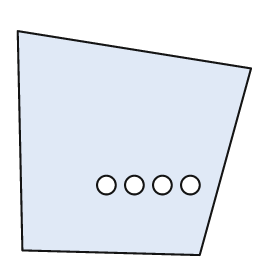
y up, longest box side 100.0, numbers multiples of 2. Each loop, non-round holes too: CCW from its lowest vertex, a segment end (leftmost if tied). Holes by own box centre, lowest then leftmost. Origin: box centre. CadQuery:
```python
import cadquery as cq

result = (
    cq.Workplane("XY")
    .moveTo(28.0, -48.0)
    .lineTo(50.0, 32.0)
    .lineTo(-50.0, 48.0)
    .lineTo(-48.0, -46.0)
    .close()
    .moveTo(-12.0, -18.0)
    .circle(4.0)
    .moveTo(0.0, -18.0)
    .circle(4.0)
    .moveTo(12.0, -18.0)
    .circle(4.0)
    .moveTo(24.0, -18.0)
    .circle(4.0)
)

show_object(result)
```